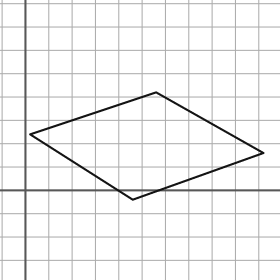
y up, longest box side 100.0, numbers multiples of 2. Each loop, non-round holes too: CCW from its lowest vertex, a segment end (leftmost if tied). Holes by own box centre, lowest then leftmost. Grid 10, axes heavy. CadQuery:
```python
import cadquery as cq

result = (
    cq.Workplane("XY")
    .moveTo(46.0, -4.0)
    .lineTo(102.0, 16.0)
    .lineTo(56.0, 42.0)
    .lineTo(2.0, 24.0)
    .close()
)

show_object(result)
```